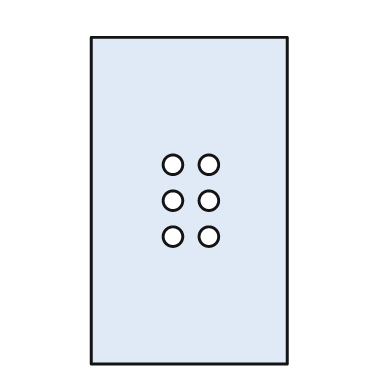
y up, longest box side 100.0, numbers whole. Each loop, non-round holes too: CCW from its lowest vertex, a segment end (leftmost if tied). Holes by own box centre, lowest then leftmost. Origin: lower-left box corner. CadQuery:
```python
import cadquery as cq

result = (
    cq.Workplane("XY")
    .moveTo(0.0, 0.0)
    .lineTo(60.0, 0.0)
    .lineTo(60.0, 100.0)
    .lineTo(0.0, 100.0)
    .close()
    .moveTo(25.0, 39.0)
    .circle(3.0)
    .moveTo(36.0, 39.0)
    .circle(3.0)
    .moveTo(25.0, 50.0)
    .circle(3.0)
    .moveTo(36.0, 50.0)
    .circle(3.0)
    .moveTo(25.0, 61.0)
    .circle(3.0)
    .moveTo(36.0, 61.0)
    .circle(3.0)
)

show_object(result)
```